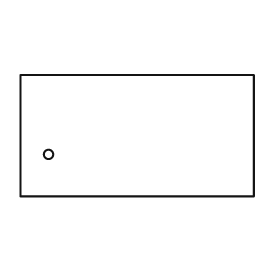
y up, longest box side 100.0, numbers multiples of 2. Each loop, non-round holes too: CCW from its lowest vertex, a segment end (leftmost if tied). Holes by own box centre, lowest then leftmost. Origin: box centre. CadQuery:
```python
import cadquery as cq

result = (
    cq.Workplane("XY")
    .moveTo(-50.0, -26.0)
    .lineTo(50.0, -26.0)
    .lineTo(50.0, 26.0)
    .lineTo(-50.0, 26.0)
    .close()
    .moveTo(-38.0, -8.0)
    .circle(2.0)
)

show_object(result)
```